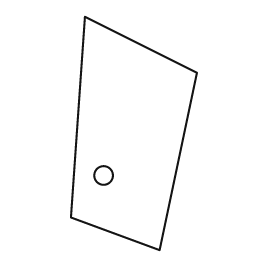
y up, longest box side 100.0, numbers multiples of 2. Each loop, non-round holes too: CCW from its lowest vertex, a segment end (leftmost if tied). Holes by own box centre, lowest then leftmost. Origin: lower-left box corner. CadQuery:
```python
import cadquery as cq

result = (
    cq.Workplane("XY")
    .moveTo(38.0, 0.0)
    .lineTo(54.0, 76.0)
    .lineTo(6.0, 100.0)
    .lineTo(0.0, 14.0)
    .close()
    .moveTo(14.0, 32.0)
    .circle(4.0)
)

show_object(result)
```